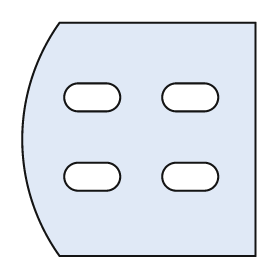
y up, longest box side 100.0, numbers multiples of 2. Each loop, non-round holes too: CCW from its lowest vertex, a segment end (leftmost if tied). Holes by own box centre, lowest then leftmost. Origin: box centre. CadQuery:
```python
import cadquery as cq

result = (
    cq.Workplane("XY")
    .moveTo(-34.0, -50.0)
    .lineTo(50.0, -50.0)
    .lineTo(50.0, 50.0)
    .lineTo(-34.0, 50.0)
    .threePointArc((-50.0, 0.0), (-34.0, -50.0))
    .close()
    .moveTo(-26.0, -22.0)
    .lineTo(-14.0, -22.0)
    .threePointArc((-8.0, -16.0), (-14.0, -10.0))
    .lineTo(-26.0, -10.0)
    .threePointArc((-32.0, -16.0), (-26.0, -22.0))
    .close()
    .moveTo(16.0, -22.0)
    .lineTo(28.0, -22.0)
    .threePointArc((34.0, -16.0), (28.0, -10.0))
    .lineTo(16.0, -10.0)
    .threePointArc((10.0, -16.0), (16.0, -22.0))
    .close()
    .moveTo(-26.0, 12.0)
    .lineTo(-14.0, 12.0)
    .threePointArc((-8.0, 18.0), (-14.0, 24.0))
    .lineTo(-26.0, 24.0)
    .threePointArc((-32.0, 18.0), (-26.0, 12.0))
    .close()
    .moveTo(16.0, 12.0)
    .lineTo(28.0, 12.0)
    .threePointArc((34.0, 18.0), (28.0, 24.0))
    .lineTo(16.0, 24.0)
    .threePointArc((10.0, 18.0), (16.0, 12.0))
    .close()
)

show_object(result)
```